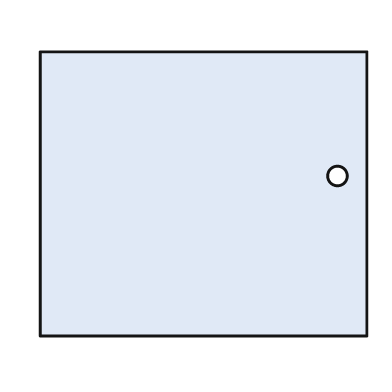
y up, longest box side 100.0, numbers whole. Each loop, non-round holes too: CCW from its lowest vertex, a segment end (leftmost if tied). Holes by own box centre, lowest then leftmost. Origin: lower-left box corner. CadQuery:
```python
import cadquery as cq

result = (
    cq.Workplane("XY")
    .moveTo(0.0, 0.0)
    .lineTo(100.0, 0.0)
    .lineTo(100.0, 87.0)
    .lineTo(0.0, 87.0)
    .close()
    .moveTo(91.0, 49.0)
    .circle(3.0)
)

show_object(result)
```